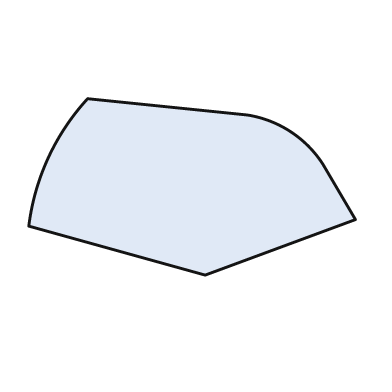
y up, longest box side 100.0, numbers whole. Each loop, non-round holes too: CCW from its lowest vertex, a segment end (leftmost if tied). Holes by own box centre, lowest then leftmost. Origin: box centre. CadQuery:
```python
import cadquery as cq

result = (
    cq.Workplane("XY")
    .moveTo(4.0, -27.0)
    .lineTo(50.0, -10.0)
    .lineTo(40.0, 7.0)
    .threePointArc((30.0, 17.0), (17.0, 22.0))
    .lineTo(-32.0, 27.0)
    .threePointArc((-44.0, 9.0), (-50.0, -12.0))
    .close()
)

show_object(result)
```